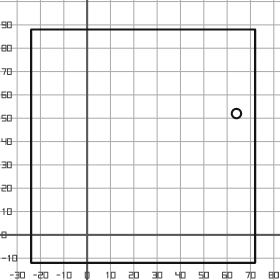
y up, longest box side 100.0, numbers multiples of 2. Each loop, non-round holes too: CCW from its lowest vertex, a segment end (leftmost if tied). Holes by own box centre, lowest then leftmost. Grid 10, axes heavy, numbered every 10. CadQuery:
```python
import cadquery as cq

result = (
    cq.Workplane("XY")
    .moveTo(-24.0, -12.0)
    .lineTo(72.0, -12.0)
    .lineTo(72.0, 88.0)
    .lineTo(-24.0, 88.0)
    .close()
    .moveTo(64.0, 52.0)
    .circle(2.0)
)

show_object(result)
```